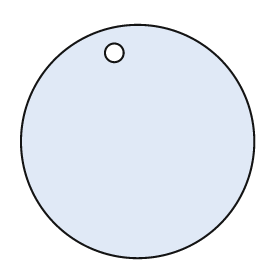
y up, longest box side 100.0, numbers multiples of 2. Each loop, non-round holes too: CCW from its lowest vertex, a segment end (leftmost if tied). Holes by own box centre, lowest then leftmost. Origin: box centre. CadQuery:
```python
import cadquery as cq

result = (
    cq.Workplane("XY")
    .moveTo(0.0, 0.0)
    .circle(50.0)
    .moveTo(-10.0, 38.0)
    .circle(4.0)
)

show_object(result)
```